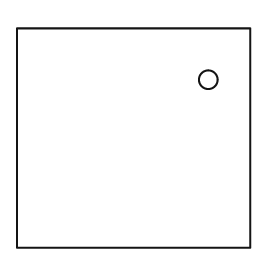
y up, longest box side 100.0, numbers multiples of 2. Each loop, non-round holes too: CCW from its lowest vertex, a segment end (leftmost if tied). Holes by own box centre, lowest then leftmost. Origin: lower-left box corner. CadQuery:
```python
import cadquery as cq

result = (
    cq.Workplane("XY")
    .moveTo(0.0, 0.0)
    .lineTo(100.0, 0.0)
    .lineTo(100.0, 94.0)
    .lineTo(0.0, 94.0)
    .close()
    .moveTo(82.0, 72.0)
    .circle(4.0)
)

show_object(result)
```